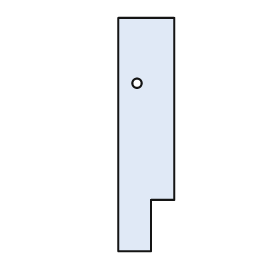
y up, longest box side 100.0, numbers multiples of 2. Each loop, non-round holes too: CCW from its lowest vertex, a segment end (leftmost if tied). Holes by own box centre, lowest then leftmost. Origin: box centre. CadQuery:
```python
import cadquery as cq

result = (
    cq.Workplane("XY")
    .moveTo(-12.0, -50.0)
    .lineTo(2.0, -50.0)
    .lineTo(2.0, -28.0)
    .lineTo(12.0, -28.0)
    .lineTo(12.0, 50.0)
    .lineTo(-12.0, 50.0)
    .close()
    .moveTo(-4.0, 22.0)
    .circle(2.0)
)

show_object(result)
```